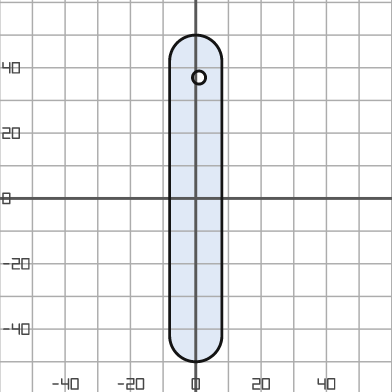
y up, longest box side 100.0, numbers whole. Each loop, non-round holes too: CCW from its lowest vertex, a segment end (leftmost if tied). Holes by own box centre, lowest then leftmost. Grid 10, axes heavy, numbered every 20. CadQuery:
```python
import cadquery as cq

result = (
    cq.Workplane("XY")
    .moveTo(-8.0, -42.0)
    .threePointArc((0.0, -50.0), (8.0, -42.0))
    .lineTo(8.0, 42.0)
    .threePointArc((0.0, 50.0), (-8.0, 42.0))
    .close()
    .moveTo(1.0, 37.0)
    .circle(2.0)
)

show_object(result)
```